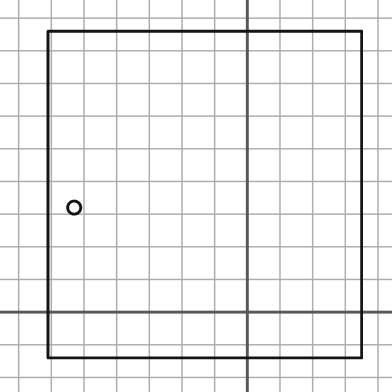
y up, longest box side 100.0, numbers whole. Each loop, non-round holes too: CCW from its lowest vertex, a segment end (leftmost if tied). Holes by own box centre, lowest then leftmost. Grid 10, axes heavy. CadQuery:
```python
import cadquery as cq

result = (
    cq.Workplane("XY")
    .moveTo(-61.0, -14.0)
    .lineTo(35.0, -14.0)
    .lineTo(35.0, 86.0)
    .lineTo(-61.0, 86.0)
    .close()
    .moveTo(-53.0, 32.0)
    .circle(2.0)
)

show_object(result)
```